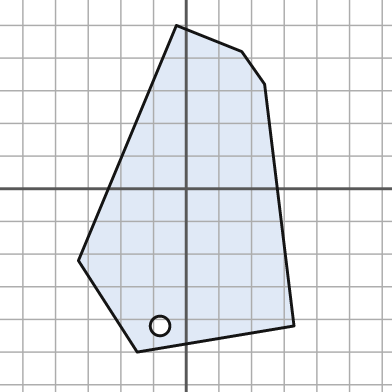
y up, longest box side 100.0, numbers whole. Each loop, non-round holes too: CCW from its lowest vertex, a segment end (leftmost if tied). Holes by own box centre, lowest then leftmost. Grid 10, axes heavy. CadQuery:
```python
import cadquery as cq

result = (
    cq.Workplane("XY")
    .moveTo(-15.0, -50.0)
    .lineTo(33.0, -42.0)
    .lineTo(24.0, 32.0)
    .lineTo(17.0, 42.0)
    .lineTo(-3.0, 50.0)
    .lineTo(-33.0, -22.0)
    .close()
    .moveTo(-8.0, -42.0)
    .circle(3.0)
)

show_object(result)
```